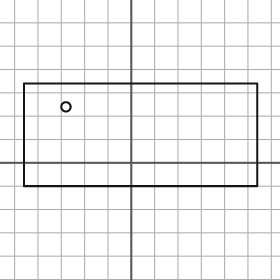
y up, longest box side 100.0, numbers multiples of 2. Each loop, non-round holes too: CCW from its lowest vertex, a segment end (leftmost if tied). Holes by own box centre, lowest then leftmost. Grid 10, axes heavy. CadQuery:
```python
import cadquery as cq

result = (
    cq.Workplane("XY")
    .moveTo(-46.0, -10.0)
    .lineTo(54.0, -10.0)
    .lineTo(54.0, 34.0)
    .lineTo(-46.0, 34.0)
    .close()
    .moveTo(-28.0, 24.0)
    .circle(2.0)
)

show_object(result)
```